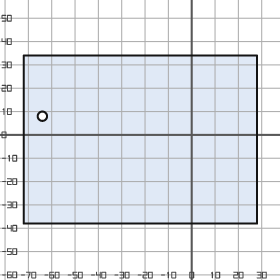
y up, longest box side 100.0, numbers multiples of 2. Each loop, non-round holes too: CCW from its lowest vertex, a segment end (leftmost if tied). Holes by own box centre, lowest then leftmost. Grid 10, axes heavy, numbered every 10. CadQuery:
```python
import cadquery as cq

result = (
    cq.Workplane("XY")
    .moveTo(-72.0, -38.0)
    .lineTo(28.0, -38.0)
    .lineTo(28.0, 34.0)
    .lineTo(-72.0, 34.0)
    .close()
    .moveTo(-64.0, 8.0)
    .circle(2.0)
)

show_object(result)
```